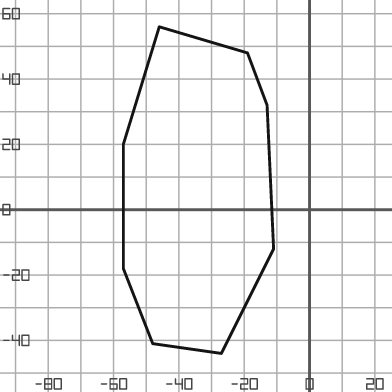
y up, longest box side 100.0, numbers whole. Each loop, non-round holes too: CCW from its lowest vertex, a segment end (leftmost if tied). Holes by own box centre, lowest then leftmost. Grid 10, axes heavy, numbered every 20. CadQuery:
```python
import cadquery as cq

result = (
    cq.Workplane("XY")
    .moveTo(-27.0, -44.0)
    .lineTo(-11.0, -12.0)
    .lineTo(-13.0, 32.0)
    .lineTo(-19.0, 48.0)
    .lineTo(-46.0, 56.0)
    .lineTo(-57.0, 20.0)
    .lineTo(-57.0, -18.0)
    .lineTo(-48.0, -41.0)
    .close()
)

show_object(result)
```